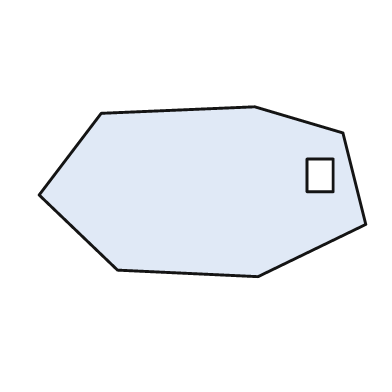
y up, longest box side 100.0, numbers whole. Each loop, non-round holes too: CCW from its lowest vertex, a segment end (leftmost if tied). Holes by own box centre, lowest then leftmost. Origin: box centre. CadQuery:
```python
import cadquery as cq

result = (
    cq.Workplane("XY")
    .moveTo(17.0, -26.0)
    .lineTo(50.0, -10.0)
    .lineTo(43.0, 18.0)
    .lineTo(16.0, 26.0)
    .lineTo(-31.0, 24.0)
    .lineTo(-50.0, -1.0)
    .lineTo(-26.0, -24.0)
    .close()
    .moveTo(32.0, 0.0)
    .lineTo(40.0, 0.0)
    .lineTo(40.0, 10.0)
    .lineTo(32.0, 10.0)
    .close()
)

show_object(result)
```